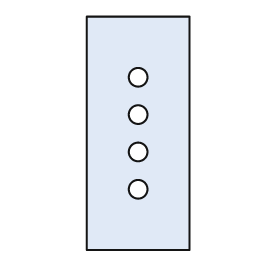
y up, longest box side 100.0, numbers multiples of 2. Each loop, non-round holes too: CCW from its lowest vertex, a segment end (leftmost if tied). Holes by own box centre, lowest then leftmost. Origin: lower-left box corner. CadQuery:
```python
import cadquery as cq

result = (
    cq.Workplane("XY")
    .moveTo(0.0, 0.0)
    .lineTo(44.0, 0.0)
    .lineTo(44.0, 100.0)
    .lineTo(0.0, 100.0)
    .close()
    .moveTo(22.0, 26.0)
    .circle(4.0)
    .moveTo(22.0, 42.0)
    .circle(4.0)
    .moveTo(22.0, 58.0)
    .circle(4.0)
    .moveTo(22.0, 74.0)
    .circle(4.0)
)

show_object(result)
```